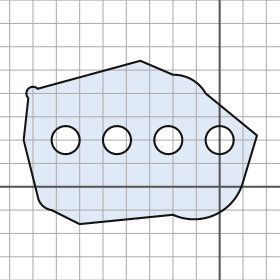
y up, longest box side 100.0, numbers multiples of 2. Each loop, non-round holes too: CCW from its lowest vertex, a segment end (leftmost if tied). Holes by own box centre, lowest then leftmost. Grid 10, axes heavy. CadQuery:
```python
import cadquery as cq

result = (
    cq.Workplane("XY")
    .moveTo(-60.0, -16.0)
    .lineTo(-20.0, -12.0)
    .threePointArc((-2.0, -12.0), (10.0, 2.0))
    .lineTo(16.0, 22.0)
    .lineTo(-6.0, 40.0)
    .threePointArc((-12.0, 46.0), (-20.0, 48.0))
    .lineTo(-34.0, 54.0)
    .lineTo(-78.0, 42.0)
    .threePointArc((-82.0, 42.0), (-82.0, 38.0))
    .lineTo(-84.0, 20.0)
    .lineTo(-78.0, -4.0)
    .threePointArc((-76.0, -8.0), (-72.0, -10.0))
    .close()
    .moveTo(-66.0, 20.0)
    .circle(6.0)
    .moveTo(-44.0, 20.0)
    .circle(6.0)
    .moveTo(-22.0, 20.0)
    .circle(6.0)
    .moveTo(0.0, 20.0)
    .circle(6.0)
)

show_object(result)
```